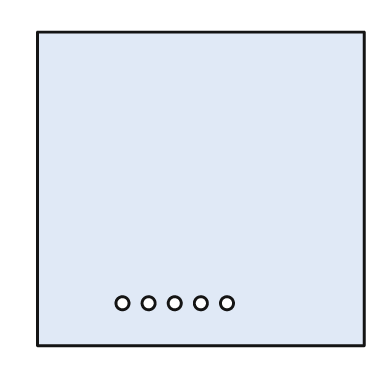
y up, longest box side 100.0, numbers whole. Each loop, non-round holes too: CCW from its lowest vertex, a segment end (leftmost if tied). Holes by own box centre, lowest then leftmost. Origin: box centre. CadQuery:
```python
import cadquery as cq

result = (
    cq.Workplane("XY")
    .moveTo(-50.0, -48.0)
    .lineTo(50.0, -48.0)
    .lineTo(50.0, 48.0)
    .lineTo(-50.0, 48.0)
    .close()
    .moveTo(-24.0, -35.0)
    .circle(2.0)
    .moveTo(-16.0, -35.0)
    .circle(2.0)
    .moveTo(-8.0, -35.0)
    .circle(2.0)
    .moveTo(0.0, -35.0)
    .circle(2.0)
    .moveTo(8.0, -35.0)
    .circle(2.0)
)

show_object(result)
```